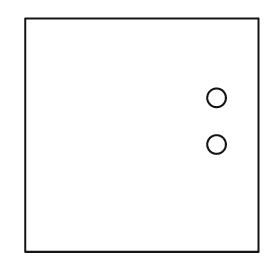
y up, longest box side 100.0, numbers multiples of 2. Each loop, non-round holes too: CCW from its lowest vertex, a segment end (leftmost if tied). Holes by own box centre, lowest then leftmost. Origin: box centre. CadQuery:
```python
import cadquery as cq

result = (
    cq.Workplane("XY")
    .moveTo(-50.0, -50.0)
    .lineTo(50.0, -50.0)
    .lineTo(50.0, 50.0)
    .lineTo(-50.0, 50.0)
    .close()
    .moveTo(32.0, -4.0)
    .circle(4.0)
    .moveTo(32.0, 16.0)
    .circle(4.0)
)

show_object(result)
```